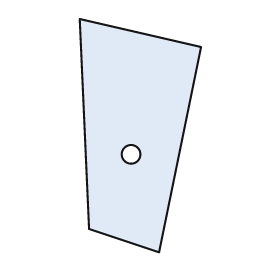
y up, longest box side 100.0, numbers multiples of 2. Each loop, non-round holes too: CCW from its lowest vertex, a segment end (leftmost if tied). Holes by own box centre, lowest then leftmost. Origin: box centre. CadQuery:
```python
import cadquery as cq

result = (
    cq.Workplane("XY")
    .moveTo(8.0, -50.0)
    .lineTo(26.0, 38.0)
    .lineTo(-26.0, 50.0)
    .lineTo(-22.0, -40.0)
    .close()
    .moveTo(-4.0, -8.0)
    .circle(4.0)
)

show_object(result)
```